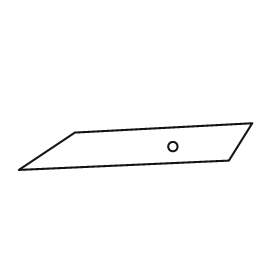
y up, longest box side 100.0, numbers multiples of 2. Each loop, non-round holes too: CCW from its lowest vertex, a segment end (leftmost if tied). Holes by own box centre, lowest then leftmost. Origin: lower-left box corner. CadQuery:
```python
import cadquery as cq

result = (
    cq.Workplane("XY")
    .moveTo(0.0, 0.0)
    .lineTo(90.0, 4.0)
    .lineTo(100.0, 20.0)
    .lineTo(24.0, 16.0)
    .close()
    .moveTo(66.0, 10.0)
    .circle(2.0)
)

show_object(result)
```